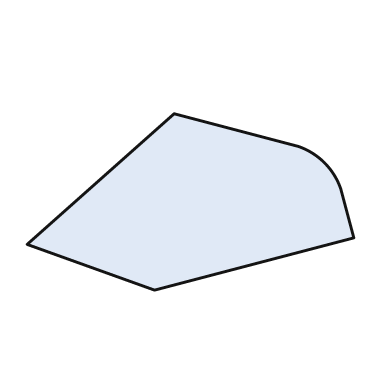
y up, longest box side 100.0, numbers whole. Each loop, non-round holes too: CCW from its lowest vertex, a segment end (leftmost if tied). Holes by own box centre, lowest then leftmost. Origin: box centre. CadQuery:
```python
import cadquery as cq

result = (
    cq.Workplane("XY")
    .moveTo(-11.0, -27.0)
    .lineTo(50.0, -11.0)
    .lineTo(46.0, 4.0)
    .threePointArc((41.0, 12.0), (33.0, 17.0))
    .lineTo(-5.0, 27.0)
    .lineTo(-50.0, -13.0)
    .close()
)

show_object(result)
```